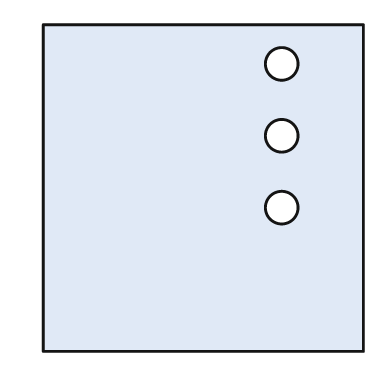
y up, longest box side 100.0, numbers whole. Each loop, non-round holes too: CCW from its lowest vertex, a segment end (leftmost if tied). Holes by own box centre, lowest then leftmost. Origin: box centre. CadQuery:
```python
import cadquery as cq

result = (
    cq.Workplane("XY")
    .moveTo(-49.0, -50.0)
    .lineTo(49.0, -50.0)
    .lineTo(49.0, 50.0)
    .lineTo(-49.0, 50.0)
    .close()
    .moveTo(24.0, -6.0)
    .circle(5.0)
    .moveTo(24.0, 16.0)
    .circle(5.0)
    .moveTo(24.0, 38.0)
    .circle(5.0)
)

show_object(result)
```